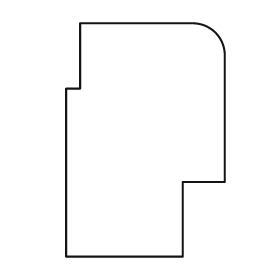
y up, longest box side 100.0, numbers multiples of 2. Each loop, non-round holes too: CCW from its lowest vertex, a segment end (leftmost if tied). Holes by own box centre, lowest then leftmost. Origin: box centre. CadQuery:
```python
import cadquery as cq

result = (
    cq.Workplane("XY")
    .moveTo(-34.0, -50.0)
    .lineTo(16.0, -50.0)
    .lineTo(16.0, -18.0)
    .lineTo(34.0, -18.0)
    .lineTo(34.0, 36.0)
    .threePointArc((30.0, 46.0), (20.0, 50.0))
    .lineTo(-28.0, 50.0)
    .lineTo(-28.0, 22.0)
    .lineTo(-34.0, 22.0)
    .close()
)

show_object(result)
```